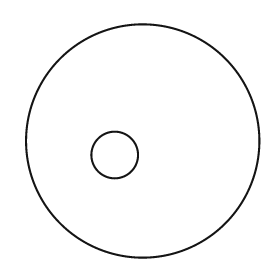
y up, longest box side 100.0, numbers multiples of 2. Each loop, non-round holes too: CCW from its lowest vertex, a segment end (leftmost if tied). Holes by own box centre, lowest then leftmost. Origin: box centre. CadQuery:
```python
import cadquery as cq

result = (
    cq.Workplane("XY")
    .moveTo(0.0, 0.0)
    .circle(50.0)
    .moveTo(-12.0, -6.0)
    .circle(10.0)
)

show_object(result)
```